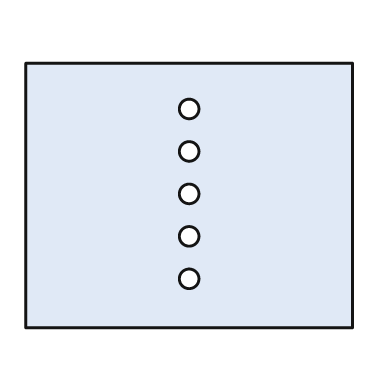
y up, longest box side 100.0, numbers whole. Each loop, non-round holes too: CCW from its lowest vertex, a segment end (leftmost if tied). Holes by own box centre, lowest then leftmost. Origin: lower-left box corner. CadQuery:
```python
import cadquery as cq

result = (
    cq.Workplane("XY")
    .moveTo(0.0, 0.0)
    .lineTo(100.0, 0.0)
    .lineTo(100.0, 81.0)
    .lineTo(0.0, 81.0)
    .close()
    .moveTo(50.0, 15.0)
    .circle(3.0)
    .moveTo(50.0, 28.0)
    .circle(3.0)
    .moveTo(50.0, 41.0)
    .circle(3.0)
    .moveTo(50.0, 54.0)
    .circle(3.0)
    .moveTo(50.0, 67.0)
    .circle(3.0)
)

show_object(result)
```